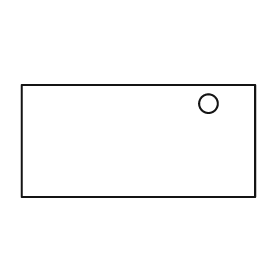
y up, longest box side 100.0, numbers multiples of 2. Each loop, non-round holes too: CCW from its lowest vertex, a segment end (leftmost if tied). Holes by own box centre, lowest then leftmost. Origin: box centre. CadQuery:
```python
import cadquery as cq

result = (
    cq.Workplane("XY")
    .moveTo(-50.0, -24.0)
    .lineTo(50.0, -24.0)
    .lineTo(50.0, 24.0)
    .lineTo(-50.0, 24.0)
    .close()
    .moveTo(30.0, 16.0)
    .circle(4.0)
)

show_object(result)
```